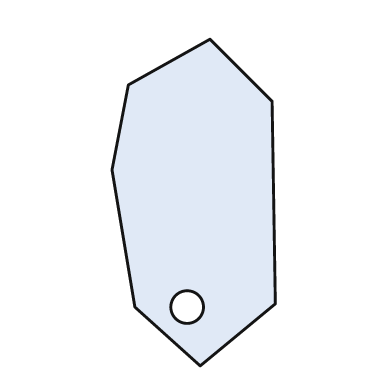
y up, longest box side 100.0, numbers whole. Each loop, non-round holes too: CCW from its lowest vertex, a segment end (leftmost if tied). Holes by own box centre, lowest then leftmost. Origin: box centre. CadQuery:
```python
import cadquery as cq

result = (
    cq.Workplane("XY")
    .moveTo(2.0, -50.0)
    .lineTo(25.0, -31.0)
    .lineTo(24.0, 31.0)
    .lineTo(5.0, 50.0)
    .lineTo(-20.0, 36.0)
    .lineTo(-25.0, 10.0)
    .lineTo(-18.0, -32.0)
    .close()
    .moveTo(-2.0, -32.0)
    .circle(5.0)
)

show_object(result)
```